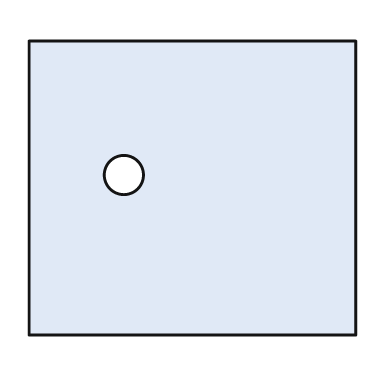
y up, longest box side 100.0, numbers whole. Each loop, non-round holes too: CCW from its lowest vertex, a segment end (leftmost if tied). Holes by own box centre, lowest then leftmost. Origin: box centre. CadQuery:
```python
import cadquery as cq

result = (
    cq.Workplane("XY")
    .moveTo(-50.0, -45.0)
    .lineTo(50.0, -45.0)
    .lineTo(50.0, 45.0)
    .lineTo(-50.0, 45.0)
    .close()
    .moveTo(-21.0, 4.0)
    .circle(6.0)
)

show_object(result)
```